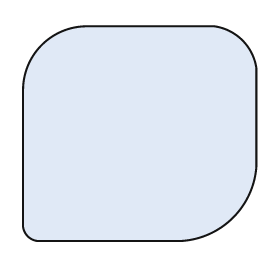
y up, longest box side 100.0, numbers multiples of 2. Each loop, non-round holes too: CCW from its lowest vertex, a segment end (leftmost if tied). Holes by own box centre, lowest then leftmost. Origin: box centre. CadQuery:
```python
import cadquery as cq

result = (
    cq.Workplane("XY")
    .moveTo(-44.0, -46.0)
    .lineTo(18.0, -46.0)
    .threePointArc((40.0, -36.0), (50.0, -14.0))
    .lineTo(50.0, 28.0)
    .threePointArc((44.0, 40.0), (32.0, 46.0))
    .lineTo(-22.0, 46.0)
    .threePointArc((-42.0, 38.0), (-50.0, 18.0))
    .lineTo(-50.0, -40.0)
    .threePointArc((-48.0, -44.0), (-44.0, -46.0))
    .close()
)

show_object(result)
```